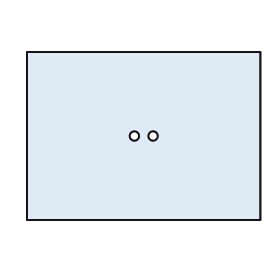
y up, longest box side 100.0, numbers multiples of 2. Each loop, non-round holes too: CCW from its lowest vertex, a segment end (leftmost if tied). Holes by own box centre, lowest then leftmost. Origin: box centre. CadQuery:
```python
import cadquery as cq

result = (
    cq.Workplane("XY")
    .moveTo(-50.0, -36.0)
    .lineTo(50.0, -36.0)
    .lineTo(50.0, 36.0)
    .lineTo(-50.0, 36.0)
    .close()
    .moveTo(-4.0, 0.0)
    .circle(2.0)
    .moveTo(4.0, 0.0)
    .circle(2.0)
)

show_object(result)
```